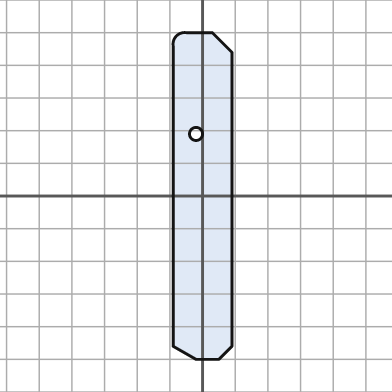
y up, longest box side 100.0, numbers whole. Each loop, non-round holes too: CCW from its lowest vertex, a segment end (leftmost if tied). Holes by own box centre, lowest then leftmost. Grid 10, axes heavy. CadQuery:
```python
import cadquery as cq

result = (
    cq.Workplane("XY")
    .moveTo(-2.0, -50.0)
    .lineTo(5.0, -50.0)
    .lineTo(9.0, -46.0)
    .lineTo(9.0, 44.0)
    .lineTo(3.0, 50.0)
    .lineTo(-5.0, 50.0)
    .threePointArc((-8.0, 49.0), (-9.0, 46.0))
    .lineTo(-9.0, -46.0)
    .close()
    .moveTo(-2.0, 19.0)
    .circle(2.0)
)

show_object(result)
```